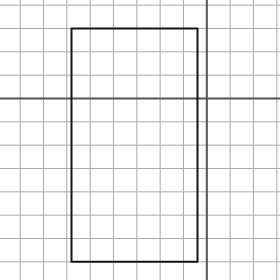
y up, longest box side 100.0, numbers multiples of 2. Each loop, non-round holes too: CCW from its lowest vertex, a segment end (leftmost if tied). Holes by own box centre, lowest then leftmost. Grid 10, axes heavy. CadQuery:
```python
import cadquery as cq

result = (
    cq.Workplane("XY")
    .moveTo(-58.0, -70.0)
    .lineTo(-4.0, -70.0)
    .lineTo(-4.0, 30.0)
    .lineTo(-58.0, 30.0)
    .close()
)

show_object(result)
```